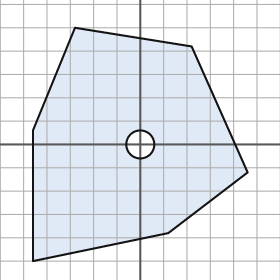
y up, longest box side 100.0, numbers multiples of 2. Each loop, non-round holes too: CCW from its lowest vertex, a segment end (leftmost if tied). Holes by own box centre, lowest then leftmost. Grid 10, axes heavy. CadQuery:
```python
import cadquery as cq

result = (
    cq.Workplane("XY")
    .moveTo(-46.0, -50.0)
    .lineTo(12.0, -38.0)
    .lineTo(46.0, -12.0)
    .lineTo(22.0, 42.0)
    .lineTo(-28.0, 50.0)
    .lineTo(-46.0, 6.0)
    .close()
    .moveTo(0.0, 0.0)
    .circle(6.0)
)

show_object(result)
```